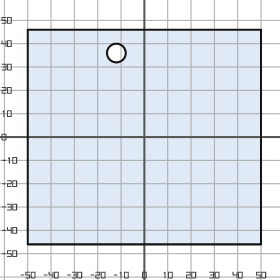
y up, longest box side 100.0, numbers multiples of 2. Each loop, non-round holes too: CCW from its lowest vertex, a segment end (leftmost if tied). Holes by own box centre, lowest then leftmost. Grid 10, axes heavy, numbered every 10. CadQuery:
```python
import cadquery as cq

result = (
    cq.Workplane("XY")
    .moveTo(-50.0, -46.0)
    .lineTo(50.0, -46.0)
    .lineTo(50.0, 46.0)
    .lineTo(-50.0, 46.0)
    .close()
    .moveTo(-12.0, 36.0)
    .circle(4.0)
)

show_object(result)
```